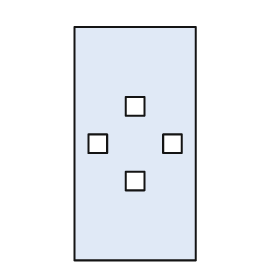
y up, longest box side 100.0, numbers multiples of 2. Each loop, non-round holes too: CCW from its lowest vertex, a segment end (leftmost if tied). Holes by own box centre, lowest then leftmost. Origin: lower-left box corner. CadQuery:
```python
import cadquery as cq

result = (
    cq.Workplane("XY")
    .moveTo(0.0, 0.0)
    .lineTo(52.0, 0.0)
    .lineTo(52.0, 100.0)
    .lineTo(0.0, 100.0)
    .close()
    .moveTo(22.0, 30.0)
    .lineTo(30.0, 30.0)
    .lineTo(30.0, 38.0)
    .lineTo(22.0, 38.0)
    .close()
    .moveTo(6.0, 46.0)
    .lineTo(14.0, 46.0)
    .lineTo(14.0, 54.0)
    .lineTo(6.0, 54.0)
    .close()
    .moveTo(38.0, 46.0)
    .lineTo(46.0, 46.0)
    .lineTo(46.0, 54.0)
    .lineTo(38.0, 54.0)
    .close()
    .moveTo(22.0, 62.0)
    .lineTo(30.0, 62.0)
    .lineTo(30.0, 70.0)
    .lineTo(22.0, 70.0)
    .close()
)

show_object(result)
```